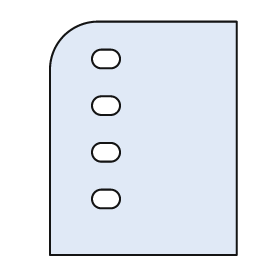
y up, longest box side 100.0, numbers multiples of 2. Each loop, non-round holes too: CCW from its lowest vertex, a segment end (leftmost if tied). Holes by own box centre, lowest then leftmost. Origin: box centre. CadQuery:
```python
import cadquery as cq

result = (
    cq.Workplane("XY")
    .moveTo(-40.0, -50.0)
    .lineTo(40.0, -50.0)
    .lineTo(40.0, 50.0)
    .lineTo(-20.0, 50.0)
    .threePointArc((-34.0, 44.0), (-40.0, 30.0))
    .close()
    .moveTo(-18.0, -30.0)
    .lineTo(-14.0, -30.0)
    .threePointArc((-10.0, -26.0), (-14.0, -22.0))
    .lineTo(-18.0, -22.0)
    .threePointArc((-22.0, -26.0), (-18.0, -30.0))
    .close()
    .moveTo(-18.0, -10.0)
    .lineTo(-14.0, -10.0)
    .threePointArc((-10.0, -6.0), (-14.0, -2.0))
    .lineTo(-18.0, -2.0)
    .threePointArc((-22.0, -6.0), (-18.0, -10.0))
    .close()
    .moveTo(-18.0, 10.0)
    .lineTo(-14.0, 10.0)
    .threePointArc((-10.0, 14.0), (-14.0, 18.0))
    .lineTo(-18.0, 18.0)
    .threePointArc((-22.0, 14.0), (-18.0, 10.0))
    .close()
    .moveTo(-18.0, 30.0)
    .lineTo(-14.0, 30.0)
    .threePointArc((-10.0, 34.0), (-14.0, 38.0))
    .lineTo(-18.0, 38.0)
    .threePointArc((-22.0, 34.0), (-18.0, 30.0))
    .close()
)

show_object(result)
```